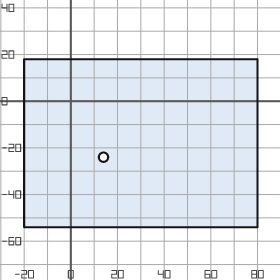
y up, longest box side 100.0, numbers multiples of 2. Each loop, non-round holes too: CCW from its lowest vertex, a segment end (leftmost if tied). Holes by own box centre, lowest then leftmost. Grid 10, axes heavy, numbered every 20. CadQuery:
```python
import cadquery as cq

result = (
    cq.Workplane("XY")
    .moveTo(-20.0, -54.0)
    .lineTo(80.0, -54.0)
    .lineTo(80.0, 18.0)
    .lineTo(-20.0, 18.0)
    .close()
    .moveTo(14.0, -24.0)
    .circle(2.0)
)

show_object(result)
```